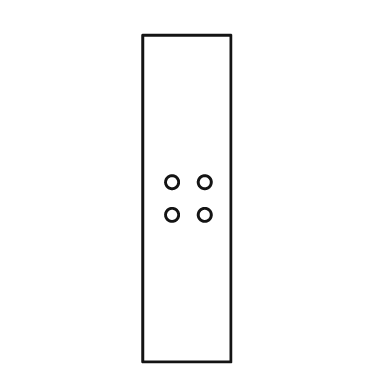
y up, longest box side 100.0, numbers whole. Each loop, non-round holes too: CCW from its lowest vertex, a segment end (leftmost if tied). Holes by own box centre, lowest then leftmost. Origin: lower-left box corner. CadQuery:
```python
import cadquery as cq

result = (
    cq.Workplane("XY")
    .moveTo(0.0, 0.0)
    .lineTo(27.0, 0.0)
    .lineTo(27.0, 100.0)
    .lineTo(0.0, 100.0)
    .close()
    .moveTo(9.0, 45.0)
    .circle(2.0)
    .moveTo(19.0, 45.0)
    .circle(2.0)
    .moveTo(9.0, 55.0)
    .circle(2.0)
    .moveTo(19.0, 55.0)
    .circle(2.0)
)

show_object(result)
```